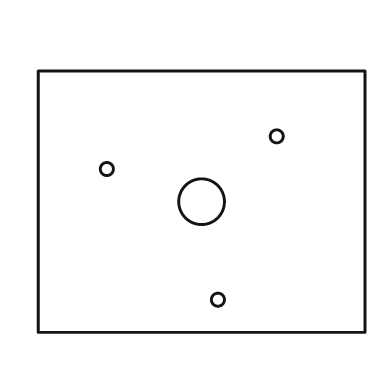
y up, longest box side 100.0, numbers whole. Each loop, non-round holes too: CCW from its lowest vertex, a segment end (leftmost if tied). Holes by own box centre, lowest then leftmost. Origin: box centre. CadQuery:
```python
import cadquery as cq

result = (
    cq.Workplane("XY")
    .moveTo(-50.0, -40.0)
    .lineTo(50.0, -40.0)
    .lineTo(50.0, 40.0)
    .lineTo(-50.0, 40.0)
    .close()
    .moveTo(5.0, -30.0)
    .circle(2.0)
    .moveTo(0.0, 0.0)
    .circle(7.0)
    .moveTo(-29.0, 10.0)
    .circle(2.0)
    .moveTo(23.0, 20.0)
    .circle(2.0)
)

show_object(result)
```